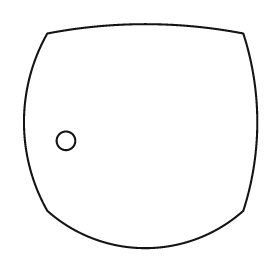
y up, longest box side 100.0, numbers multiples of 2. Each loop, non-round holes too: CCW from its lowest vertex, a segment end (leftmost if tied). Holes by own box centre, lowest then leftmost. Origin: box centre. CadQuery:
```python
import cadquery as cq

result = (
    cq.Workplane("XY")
    .moveTo(-40.0, -32.0)
    .threePointArc((2.0, -48.0), (44.0, -32.0))
    .threePointArc((50.0, 6.0), (44.0, 44.0))
    .threePointArc((2.0, 48.0), (-40.0, 44.0))
    .threePointArc((-50.0, 6.0), (-40.0, -32.0))
    .close()
    .moveTo(-32.0, -2.0)
    .circle(4.0)
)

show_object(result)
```